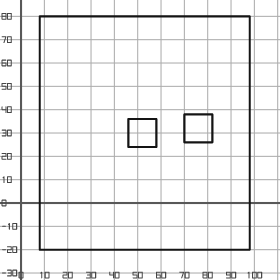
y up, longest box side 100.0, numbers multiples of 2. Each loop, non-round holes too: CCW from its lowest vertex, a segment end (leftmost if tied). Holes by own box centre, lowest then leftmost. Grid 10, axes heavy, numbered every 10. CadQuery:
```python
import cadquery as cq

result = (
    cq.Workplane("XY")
    .moveTo(8.0, -20.0)
    .lineTo(98.0, -20.0)
    .lineTo(98.0, 80.0)
    .lineTo(8.0, 80.0)
    .close()
    .moveTo(46.0, 24.0)
    .lineTo(58.0, 24.0)
    .lineTo(58.0, 36.0)
    .lineTo(46.0, 36.0)
    .close()
    .moveTo(70.0, 26.0)
    .lineTo(82.0, 26.0)
    .lineTo(82.0, 38.0)
    .lineTo(70.0, 38.0)
    .close()
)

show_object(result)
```